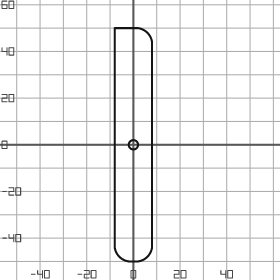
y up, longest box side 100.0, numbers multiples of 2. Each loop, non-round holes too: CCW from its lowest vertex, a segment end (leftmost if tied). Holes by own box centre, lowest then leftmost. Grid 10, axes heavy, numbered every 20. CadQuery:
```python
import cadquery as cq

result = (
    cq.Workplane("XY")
    .moveTo(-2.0, -50.0)
    .lineTo(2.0, -50.0)
    .threePointArc((6.0, -48.0), (8.0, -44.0))
    .lineTo(8.0, 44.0)
    .threePointArc((6.0, 48.0), (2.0, 50.0))
    .lineTo(-8.0, 50.0)
    .lineTo(-8.0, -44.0)
    .threePointArc((-6.0, -48.0), (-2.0, -50.0))
    .close()
    .moveTo(0.0, 0.0)
    .circle(2.0)
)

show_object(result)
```